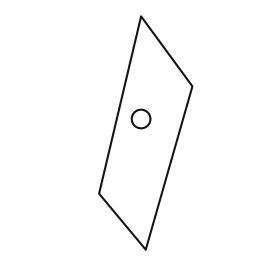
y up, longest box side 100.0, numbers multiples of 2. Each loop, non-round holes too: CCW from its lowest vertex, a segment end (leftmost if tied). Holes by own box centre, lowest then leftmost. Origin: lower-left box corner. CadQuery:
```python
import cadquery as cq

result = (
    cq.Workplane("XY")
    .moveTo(20.0, 0.0)
    .lineTo(40.0, 70.0)
    .lineTo(18.0, 100.0)
    .lineTo(0.0, 24.0)
    .close()
    .moveTo(18.0, 56.0)
    .circle(4.0)
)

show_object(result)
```